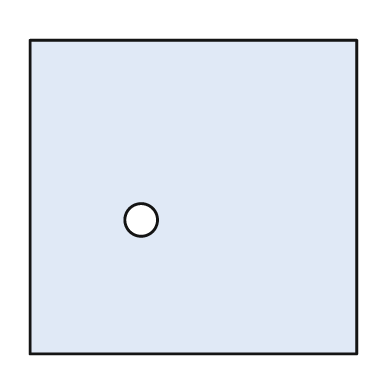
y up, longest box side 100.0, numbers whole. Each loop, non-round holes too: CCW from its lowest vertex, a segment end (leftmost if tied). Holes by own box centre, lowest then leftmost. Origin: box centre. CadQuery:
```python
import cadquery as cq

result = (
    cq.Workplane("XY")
    .moveTo(-50.0, -48.0)
    .lineTo(50.0, -48.0)
    .lineTo(50.0, 48.0)
    .lineTo(-50.0, 48.0)
    .close()
    .moveTo(-16.0, -7.0)
    .circle(5.0)
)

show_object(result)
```